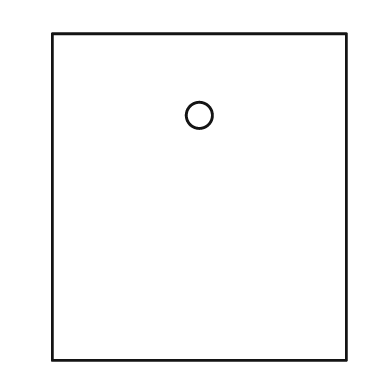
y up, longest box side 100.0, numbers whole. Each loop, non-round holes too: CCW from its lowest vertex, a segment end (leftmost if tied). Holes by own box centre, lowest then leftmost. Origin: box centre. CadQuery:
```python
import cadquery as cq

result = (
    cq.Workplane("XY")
    .moveTo(-45.0, -50.0)
    .lineTo(45.0, -50.0)
    .lineTo(45.0, 50.0)
    .lineTo(-45.0, 50.0)
    .close()
    .moveTo(0.0, 25.0)
    .circle(4.0)
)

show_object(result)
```